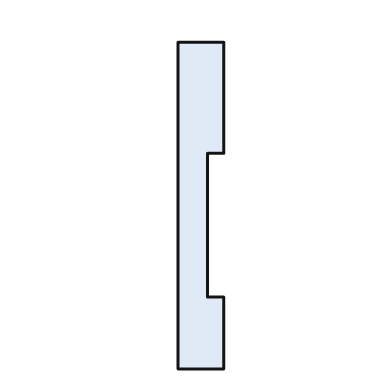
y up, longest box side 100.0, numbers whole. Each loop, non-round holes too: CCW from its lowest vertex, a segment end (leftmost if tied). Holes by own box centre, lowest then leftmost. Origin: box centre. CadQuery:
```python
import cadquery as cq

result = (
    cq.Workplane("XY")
    .moveTo(-7.0, -50.0)
    .lineTo(7.0, -50.0)
    .lineTo(7.0, -28.0)
    .lineTo(2.0, -28.0)
    .lineTo(2.0, 16.0)
    .lineTo(7.0, 16.0)
    .lineTo(7.0, 50.0)
    .lineTo(-7.0, 50.0)
    .close()
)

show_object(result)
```